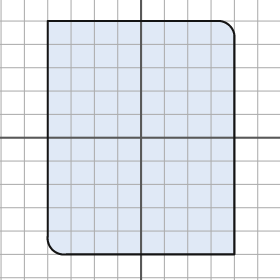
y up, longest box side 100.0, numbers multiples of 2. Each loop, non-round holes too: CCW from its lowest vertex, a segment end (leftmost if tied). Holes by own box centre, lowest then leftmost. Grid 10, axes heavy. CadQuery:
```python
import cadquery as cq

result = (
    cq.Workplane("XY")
    .moveTo(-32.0, -50.0)
    .lineTo(40.0, -50.0)
    .lineTo(40.0, 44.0)
    .threePointArc((38.0, 48.0), (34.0, 50.0))
    .lineTo(-40.0, 50.0)
    .lineTo(-40.0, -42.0)
    .threePointArc((-38.0, -48.0), (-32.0, -50.0))
    .close()
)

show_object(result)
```